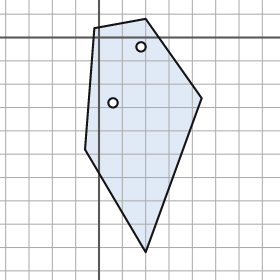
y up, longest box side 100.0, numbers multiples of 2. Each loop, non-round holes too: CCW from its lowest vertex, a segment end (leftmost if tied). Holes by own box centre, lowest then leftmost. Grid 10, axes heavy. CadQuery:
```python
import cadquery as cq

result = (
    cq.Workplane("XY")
    .moveTo(20.0, -92.0)
    .lineTo(44.0, -26.0)
    .lineTo(20.0, 8.0)
    .lineTo(-2.0, 4.0)
    .lineTo(-6.0, -48.0)
    .close()
    .moveTo(6.0, -28.0)
    .circle(2.0)
    .moveTo(18.0, -4.0)
    .circle(2.0)
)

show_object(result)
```